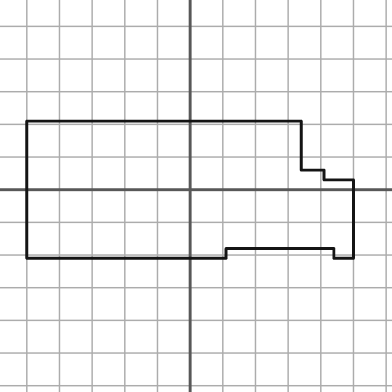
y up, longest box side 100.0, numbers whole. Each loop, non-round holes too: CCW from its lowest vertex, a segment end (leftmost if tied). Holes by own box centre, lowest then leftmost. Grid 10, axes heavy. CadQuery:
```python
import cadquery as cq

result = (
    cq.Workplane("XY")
    .moveTo(-50.0, -21.0)
    .lineTo(11.0, -21.0)
    .lineTo(11.0, -18.0)
    .lineTo(44.0, -18.0)
    .lineTo(44.0, -21.0)
    .lineTo(50.0, -21.0)
    .lineTo(50.0, 3.0)
    .lineTo(41.0, 3.0)
    .lineTo(41.0, 6.0)
    .lineTo(34.0, 6.0)
    .lineTo(34.0, 21.0)
    .lineTo(-50.0, 21.0)
    .close()
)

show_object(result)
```